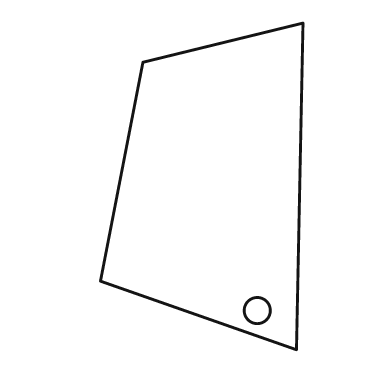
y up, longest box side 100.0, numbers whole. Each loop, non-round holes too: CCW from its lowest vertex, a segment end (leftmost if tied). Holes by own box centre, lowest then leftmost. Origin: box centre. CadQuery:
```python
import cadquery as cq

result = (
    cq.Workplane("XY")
    .moveTo(29.0, -50.0)
    .lineTo(31.0, 50.0)
    .lineTo(-18.0, 38.0)
    .lineTo(-31.0, -29.0)
    .close()
    .moveTo(17.0, -38.0)
    .circle(4.0)
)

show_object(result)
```